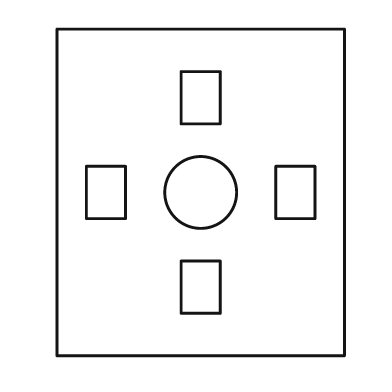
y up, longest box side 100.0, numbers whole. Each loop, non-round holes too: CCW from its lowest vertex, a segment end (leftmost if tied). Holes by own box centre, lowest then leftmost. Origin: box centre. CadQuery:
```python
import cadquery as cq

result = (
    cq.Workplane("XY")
    .moveTo(-44.0, -50.0)
    .lineTo(44.0, -50.0)
    .lineTo(44.0, 50.0)
    .lineTo(-44.0, 50.0)
    .close()
    .moveTo(-6.0, -37.0)
    .lineTo(6.0, -37.0)
    .lineTo(6.0, -21.0)
    .lineTo(-6.0, -21.0)
    .close()
    .moveTo(-35.0, -8.0)
    .lineTo(-23.0, -8.0)
    .lineTo(-23.0, 8.0)
    .lineTo(-35.0, 8.0)
    .close()
    .moveTo(0.0, 0.0)
    .circle(11.0)
    .moveTo(23.0, -8.0)
    .lineTo(35.0, -8.0)
    .lineTo(35.0, 8.0)
    .lineTo(23.0, 8.0)
    .close()
    .moveTo(-6.0, 21.0)
    .lineTo(6.0, 21.0)
    .lineTo(6.0, 37.0)
    .lineTo(-6.0, 37.0)
    .close()
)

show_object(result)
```